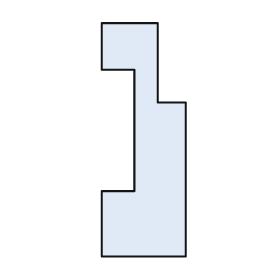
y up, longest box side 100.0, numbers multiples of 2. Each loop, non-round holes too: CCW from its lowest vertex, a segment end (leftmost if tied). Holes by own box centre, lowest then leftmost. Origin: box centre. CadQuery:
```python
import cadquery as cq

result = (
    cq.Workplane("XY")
    .moveTo(-18.0, -50.0)
    .lineTo(18.0, -50.0)
    .lineTo(18.0, 16.0)
    .lineTo(6.0, 16.0)
    .lineTo(6.0, 50.0)
    .lineTo(-18.0, 50.0)
    .lineTo(-18.0, 30.0)
    .lineTo(-4.0, 30.0)
    .lineTo(-4.0, -22.0)
    .lineTo(-18.0, -22.0)
    .close()
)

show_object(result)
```